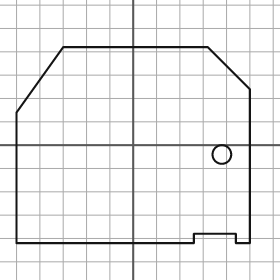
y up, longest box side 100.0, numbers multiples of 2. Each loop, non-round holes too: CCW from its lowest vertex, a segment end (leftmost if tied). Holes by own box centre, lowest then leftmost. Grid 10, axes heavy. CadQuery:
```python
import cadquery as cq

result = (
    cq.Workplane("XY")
    .moveTo(-50.0, -42.0)
    .lineTo(26.0, -42.0)
    .lineTo(26.0, -38.0)
    .lineTo(44.0, -38.0)
    .lineTo(44.0, -42.0)
    .lineTo(50.0, -42.0)
    .lineTo(50.0, 24.0)
    .lineTo(32.0, 42.0)
    .lineTo(-30.0, 42.0)
    .lineTo(-50.0, 14.0)
    .close()
    .moveTo(38.0, -4.0)
    .circle(4.0)
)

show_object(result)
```